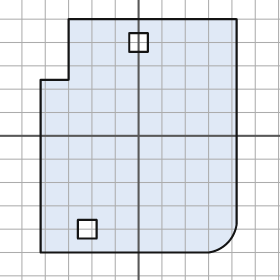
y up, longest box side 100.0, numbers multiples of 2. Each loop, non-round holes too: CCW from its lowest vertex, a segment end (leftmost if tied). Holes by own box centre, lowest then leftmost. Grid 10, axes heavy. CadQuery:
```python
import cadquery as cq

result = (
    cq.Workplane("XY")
    .moveTo(-42.0, -50.0)
    .lineTo(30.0, -50.0)
    .threePointArc((38.0, -46.0), (42.0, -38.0))
    .lineTo(42.0, 50.0)
    .lineTo(-30.0, 50.0)
    .lineTo(-30.0, 24.0)
    .lineTo(-42.0, 24.0)
    .close()
    .moveTo(-26.0, -44.0)
    .lineTo(-18.0, -44.0)
    .lineTo(-18.0, -36.0)
    .lineTo(-26.0, -36.0)
    .close()
    .moveTo(-4.0, 36.0)
    .lineTo(4.0, 36.0)
    .lineTo(4.0, 44.0)
    .lineTo(-4.0, 44.0)
    .close()
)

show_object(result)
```